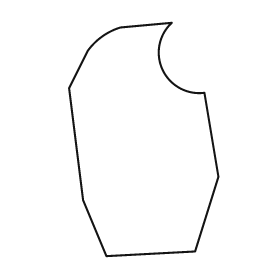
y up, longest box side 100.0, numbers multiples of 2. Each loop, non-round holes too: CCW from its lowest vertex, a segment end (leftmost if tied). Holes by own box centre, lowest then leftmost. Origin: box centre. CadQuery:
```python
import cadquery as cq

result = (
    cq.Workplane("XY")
    .moveTo(-16.0, -50.0)
    .lineTo(22.0, -48.0)
    .lineTo(32.0, -16.0)
    .lineTo(26.0, 20.0)
    .threePointArc((8.0, 30.0), (12.0, 50.0))
    .lineTo(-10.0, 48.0)
    .threePointArc((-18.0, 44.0), (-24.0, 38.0))
    .lineTo(-32.0, 22.0)
    .lineTo(-26.0, -26.0)
    .close()
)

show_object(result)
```